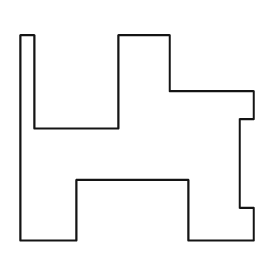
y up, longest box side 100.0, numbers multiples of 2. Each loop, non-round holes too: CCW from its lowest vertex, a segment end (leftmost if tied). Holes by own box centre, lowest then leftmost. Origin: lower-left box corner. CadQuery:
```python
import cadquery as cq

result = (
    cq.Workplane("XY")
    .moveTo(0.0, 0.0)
    .lineTo(24.0, 0.0)
    .lineTo(24.0, 26.0)
    .lineTo(72.0, 26.0)
    .lineTo(72.0, 0.0)
    .lineTo(100.0, 0.0)
    .lineTo(100.0, 14.0)
    .lineTo(94.0, 14.0)
    .lineTo(94.0, 52.0)
    .lineTo(100.0, 52.0)
    .lineTo(100.0, 64.0)
    .lineTo(64.0, 64.0)
    .lineTo(64.0, 88.0)
    .lineTo(42.0, 88.0)
    .lineTo(42.0, 48.0)
    .lineTo(6.0, 48.0)
    .lineTo(6.0, 88.0)
    .lineTo(0.0, 88.0)
    .close()
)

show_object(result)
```